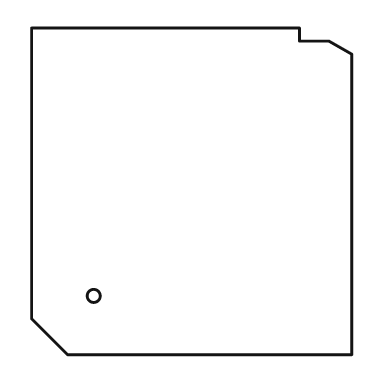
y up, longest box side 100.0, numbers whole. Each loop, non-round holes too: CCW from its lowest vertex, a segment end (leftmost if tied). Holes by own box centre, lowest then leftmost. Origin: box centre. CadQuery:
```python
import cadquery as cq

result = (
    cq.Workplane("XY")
    .moveTo(-38.0, -50.0)
    .lineTo(49.0, -50.0)
    .lineTo(49.0, 42.0)
    .lineTo(42.0, 46.0)
    .lineTo(33.0, 46.0)
    .lineTo(33.0, 50.0)
    .lineTo(-49.0, 50.0)
    .lineTo(-49.0, -39.0)
    .close()
    .moveTo(-30.0, -32.0)
    .circle(2.0)
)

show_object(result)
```